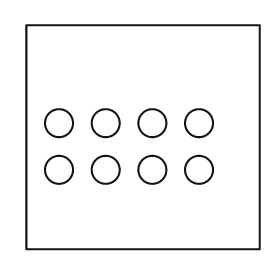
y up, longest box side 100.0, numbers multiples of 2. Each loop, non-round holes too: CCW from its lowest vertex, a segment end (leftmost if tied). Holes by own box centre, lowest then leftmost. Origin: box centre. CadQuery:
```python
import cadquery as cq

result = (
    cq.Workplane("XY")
    .moveTo(-50.0, -48.0)
    .lineTo(50.0, -48.0)
    .lineTo(50.0, 48.0)
    .lineTo(-50.0, 48.0)
    .close()
    .moveTo(-36.0, -14.0)
    .circle(6.0)
    .moveTo(-16.0, -14.0)
    .circle(6.0)
    .moveTo(4.0, -14.0)
    .circle(6.0)
    .moveTo(24.0, -14.0)
    .circle(6.0)
    .moveTo(-36.0, 6.0)
    .circle(6.0)
    .moveTo(-16.0, 6.0)
    .circle(6.0)
    .moveTo(4.0, 6.0)
    .circle(6.0)
    .moveTo(24.0, 6.0)
    .circle(6.0)
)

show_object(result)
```